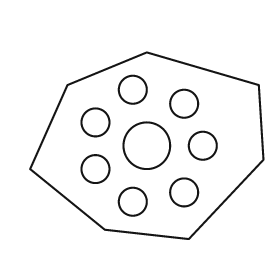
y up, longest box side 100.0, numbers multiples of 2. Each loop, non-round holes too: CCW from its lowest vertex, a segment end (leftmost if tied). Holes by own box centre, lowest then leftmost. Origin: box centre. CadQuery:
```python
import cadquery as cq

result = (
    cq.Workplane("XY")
    .moveTo(18.0, -40.0)
    .lineTo(50.0, -6.0)
    .lineTo(48.0, 26.0)
    .lineTo(0.0, 40.0)
    .lineTo(-34.0, 26.0)
    .lineTo(-50.0, -10.0)
    .lineTo(-18.0, -36.0)
    .close()
    .moveTo(-6.0, -24.0)
    .circle(6.0)
    .moveTo(16.0, -20.0)
    .circle(6.0)
    .moveTo(-22.0, -10.0)
    .circle(6.0)
    .moveTo(0.0, 0.0)
    .circle(10.0)
    .moveTo(24.0, 0.0)
    .circle(6.0)
    .moveTo(-22.0, 10.0)
    .circle(6.0)
    .moveTo(16.0, 18.0)
    .circle(6.0)
    .moveTo(-6.0, 24.0)
    .circle(6.0)
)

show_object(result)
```